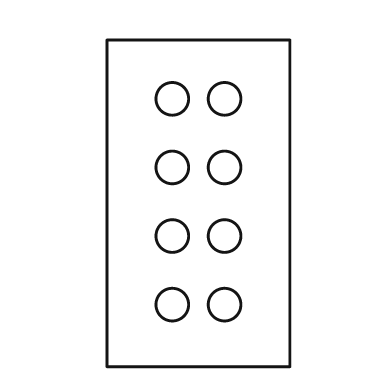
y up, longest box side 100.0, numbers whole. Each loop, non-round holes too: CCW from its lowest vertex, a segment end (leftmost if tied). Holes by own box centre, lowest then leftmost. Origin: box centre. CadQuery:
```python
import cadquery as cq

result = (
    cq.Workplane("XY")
    .moveTo(-28.0, -50.0)
    .lineTo(28.0, -50.0)
    .lineTo(28.0, 50.0)
    .lineTo(-28.0, 50.0)
    .close()
    .moveTo(-8.0, -31.0)
    .circle(5.0)
    .moveTo(8.0, -31.0)
    .circle(5.0)
    .moveTo(-8.0, -10.0)
    .circle(5.0)
    .moveTo(8.0, -10.0)
    .circle(5.0)
    .moveTo(-8.0, 11.0)
    .circle(5.0)
    .moveTo(8.0, 11.0)
    .circle(5.0)
    .moveTo(-8.0, 32.0)
    .circle(5.0)
    .moveTo(8.0, 32.0)
    .circle(5.0)
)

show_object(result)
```